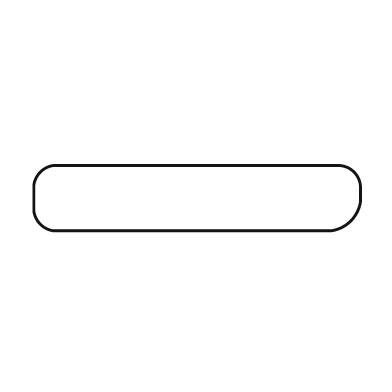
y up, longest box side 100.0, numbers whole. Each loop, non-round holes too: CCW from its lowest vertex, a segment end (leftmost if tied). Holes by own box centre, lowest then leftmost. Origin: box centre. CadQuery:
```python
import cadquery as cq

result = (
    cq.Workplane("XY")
    .moveTo(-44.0, -10.0)
    .lineTo(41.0, -10.0)
    .threePointArc((47.0, -7.0), (50.0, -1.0))
    .lineTo(50.0, 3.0)
    .threePointArc((48.0, 8.0), (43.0, 10.0))
    .lineTo(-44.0, 10.0)
    .threePointArc((-48.0, 8.0), (-50.0, 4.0))
    .lineTo(-50.0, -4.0)
    .threePointArc((-48.0, -8.0), (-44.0, -10.0))
    .close()
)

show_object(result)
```